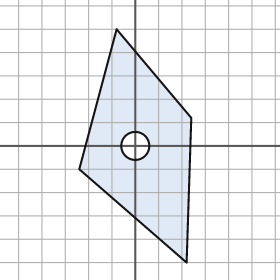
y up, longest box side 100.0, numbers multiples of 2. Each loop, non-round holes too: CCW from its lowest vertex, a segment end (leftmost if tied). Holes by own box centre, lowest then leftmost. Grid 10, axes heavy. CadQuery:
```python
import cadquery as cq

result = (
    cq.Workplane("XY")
    .moveTo(22.0, -50.0)
    .lineTo(24.0, 12.0)
    .lineTo(-8.0, 50.0)
    .lineTo(-24.0, -10.0)
    .close()
    .moveTo(0.0, 0.0)
    .circle(6.0)
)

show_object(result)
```